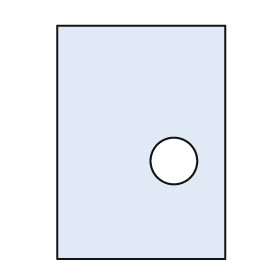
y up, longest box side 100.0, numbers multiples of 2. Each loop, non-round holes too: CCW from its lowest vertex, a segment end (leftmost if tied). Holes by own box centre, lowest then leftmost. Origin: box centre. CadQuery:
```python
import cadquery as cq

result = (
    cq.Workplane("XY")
    .moveTo(-36.0, -50.0)
    .lineTo(36.0, -50.0)
    .lineTo(36.0, 50.0)
    .lineTo(-36.0, 50.0)
    .close()
    .moveTo(14.0, -8.0)
    .circle(10.0)
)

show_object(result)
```